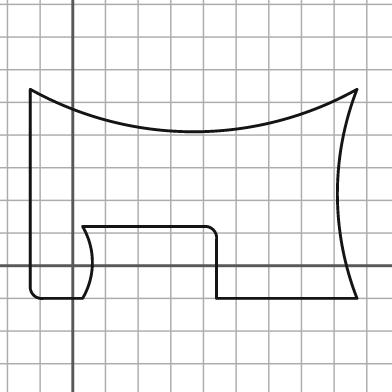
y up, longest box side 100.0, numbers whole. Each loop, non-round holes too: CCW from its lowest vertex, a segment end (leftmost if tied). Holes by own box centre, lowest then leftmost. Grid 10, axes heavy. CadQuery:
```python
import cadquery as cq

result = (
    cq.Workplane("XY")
    .moveTo(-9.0, -10.0)
    .lineTo(3.0, -10.0)
    .threePointArc((6.0, 1.0), (3.0, 12.0))
    .lineTo(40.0, 12.0)
    .threePointArc((43.0, 11.0), (44.0, 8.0))
    .lineTo(44.0, -10.0)
    .lineTo(87.0, -10.0)
    .threePointArc((81.0, 22.0), (87.0, 54.0))
    .threePointArc((37.0, 41.0), (-13.0, 54.0))
    .lineTo(-13.0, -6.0)
    .threePointArc((-12.0, -9.0), (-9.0, -10.0))
    .close()
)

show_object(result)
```